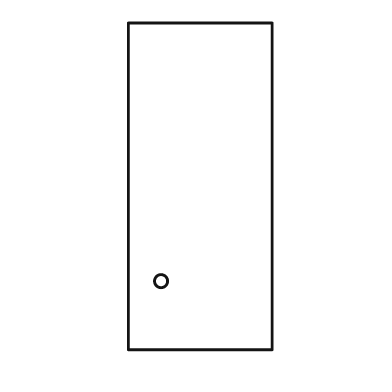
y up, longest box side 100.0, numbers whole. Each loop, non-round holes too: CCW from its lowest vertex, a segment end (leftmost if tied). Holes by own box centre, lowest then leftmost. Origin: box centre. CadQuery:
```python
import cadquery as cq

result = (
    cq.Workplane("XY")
    .moveTo(-22.0, -50.0)
    .lineTo(22.0, -50.0)
    .lineTo(22.0, 50.0)
    .lineTo(-22.0, 50.0)
    .close()
    .moveTo(-12.0, -29.0)
    .circle(2.0)
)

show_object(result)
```